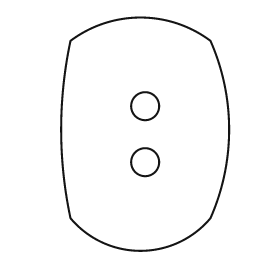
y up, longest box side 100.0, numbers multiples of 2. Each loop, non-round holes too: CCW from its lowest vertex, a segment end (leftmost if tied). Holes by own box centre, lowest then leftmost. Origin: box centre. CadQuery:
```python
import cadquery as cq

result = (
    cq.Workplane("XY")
    .moveTo(-32.0, -36.0)
    .threePointArc((-2.0, -50.0), (28.0, -36.0))
    .threePointArc((36.0, 2.0), (28.0, 40.0))
    .threePointArc((-2.0, 50.0), (-32.0, 40.0))
    .threePointArc((-36.0, 2.0), (-32.0, -36.0))
    .close()
    .moveTo(0.0, -12.0)
    .circle(6.0)
    .moveTo(0.0, 12.0)
    .circle(6.0)
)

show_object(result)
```